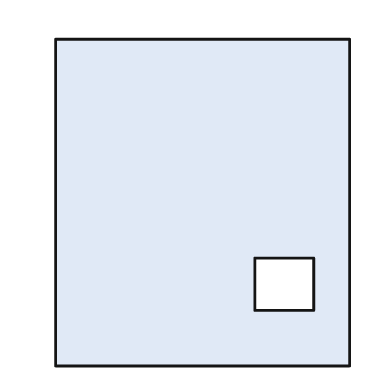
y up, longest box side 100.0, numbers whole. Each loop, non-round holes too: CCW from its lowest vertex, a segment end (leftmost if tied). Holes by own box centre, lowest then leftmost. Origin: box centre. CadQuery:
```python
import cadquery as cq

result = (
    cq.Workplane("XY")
    .moveTo(-45.0, -50.0)
    .lineTo(45.0, -50.0)
    .lineTo(45.0, 50.0)
    .lineTo(-45.0, 50.0)
    .close()
    .moveTo(16.0, -33.0)
    .lineTo(34.0, -33.0)
    .lineTo(34.0, -17.0)
    .lineTo(16.0, -17.0)
    .close()
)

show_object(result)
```